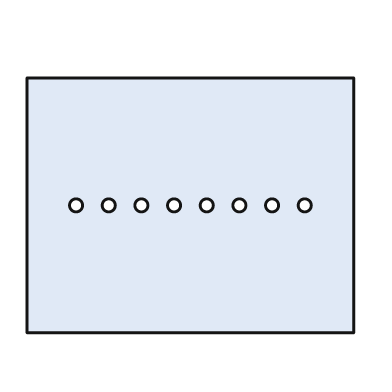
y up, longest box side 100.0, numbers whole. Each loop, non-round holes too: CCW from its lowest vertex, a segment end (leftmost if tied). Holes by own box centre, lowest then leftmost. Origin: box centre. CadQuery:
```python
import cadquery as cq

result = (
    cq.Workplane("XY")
    .moveTo(-50.0, -39.0)
    .lineTo(50.0, -39.0)
    .lineTo(50.0, 39.0)
    .lineTo(-50.0, 39.0)
    .close()
    .moveTo(-35.0, 0.0)
    .circle(2.0)
    .moveTo(-25.0, 0.0)
    .circle(2.0)
    .moveTo(-15.0, 0.0)
    .circle(2.0)
    .moveTo(-5.0, 0.0)
    .circle(2.0)
    .moveTo(5.0, 0.0)
    .circle(2.0)
    .moveTo(15.0, 0.0)
    .circle(2.0)
    .moveTo(25.0, 0.0)
    .circle(2.0)
    .moveTo(35.0, 0.0)
    .circle(2.0)
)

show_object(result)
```